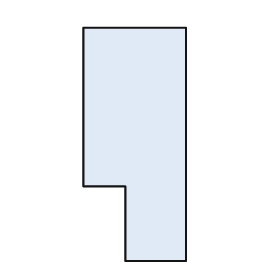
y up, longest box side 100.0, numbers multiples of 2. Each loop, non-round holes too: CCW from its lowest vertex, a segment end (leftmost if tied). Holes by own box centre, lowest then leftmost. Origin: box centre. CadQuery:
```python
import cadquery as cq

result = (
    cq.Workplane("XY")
    .moveTo(-4.0, -50.0)
    .lineTo(22.0, -50.0)
    .lineTo(22.0, 50.0)
    .lineTo(-22.0, 50.0)
    .lineTo(-22.0, -18.0)
    .lineTo(-4.0, -18.0)
    .close()
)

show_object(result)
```